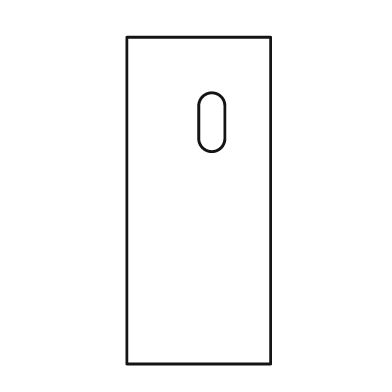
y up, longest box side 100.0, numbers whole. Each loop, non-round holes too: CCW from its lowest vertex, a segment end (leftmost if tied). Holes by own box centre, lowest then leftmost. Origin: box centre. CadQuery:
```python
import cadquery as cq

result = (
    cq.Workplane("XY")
    .moveTo(-22.0, -50.0)
    .lineTo(22.0, -50.0)
    .lineTo(22.0, 50.0)
    .lineTo(-22.0, 50.0)
    .close()
    .moveTo(0.0, 19.0)
    .threePointArc((4.0, 15.0), (8.0, 19.0))
    .lineTo(8.0, 29.0)
    .threePointArc((4.0, 33.0), (0.0, 29.0))
    .close()
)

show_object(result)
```